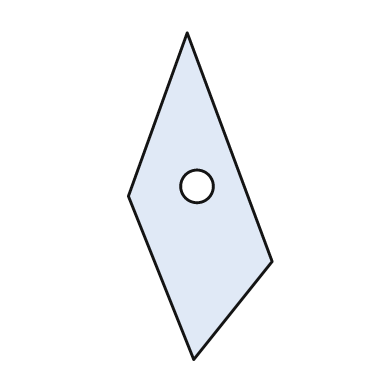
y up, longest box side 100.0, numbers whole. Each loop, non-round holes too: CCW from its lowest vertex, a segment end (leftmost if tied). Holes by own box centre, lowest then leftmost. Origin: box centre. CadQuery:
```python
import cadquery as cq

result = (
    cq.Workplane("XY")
    .moveTo(-2.0, -50.0)
    .lineTo(22.0, -20.0)
    .lineTo(-4.0, 50.0)
    .lineTo(-22.0, 0.0)
    .close()
    .moveTo(-1.0, 3.0)
    .circle(5.0)
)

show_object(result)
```